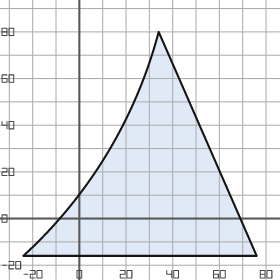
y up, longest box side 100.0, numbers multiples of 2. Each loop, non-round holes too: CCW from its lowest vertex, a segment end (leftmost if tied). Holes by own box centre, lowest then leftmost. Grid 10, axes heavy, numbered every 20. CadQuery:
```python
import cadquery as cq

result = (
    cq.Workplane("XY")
    .moveTo(-24.0, -16.0)
    .lineTo(76.0, -16.0)
    .lineTo(34.0, 80.0)
    .threePointArc((12.0, 28.0), (-24.0, -16.0))
    .close()
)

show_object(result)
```